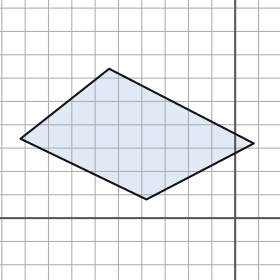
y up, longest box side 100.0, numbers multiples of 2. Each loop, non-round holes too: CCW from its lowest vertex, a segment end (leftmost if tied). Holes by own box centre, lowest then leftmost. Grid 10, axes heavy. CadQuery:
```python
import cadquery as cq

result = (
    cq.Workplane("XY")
    .moveTo(-38.0, 8.0)
    .lineTo(8.0, 32.0)
    .lineTo(-54.0, 64.0)
    .lineTo(-92.0, 34.0)
    .close()
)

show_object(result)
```